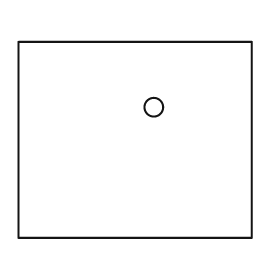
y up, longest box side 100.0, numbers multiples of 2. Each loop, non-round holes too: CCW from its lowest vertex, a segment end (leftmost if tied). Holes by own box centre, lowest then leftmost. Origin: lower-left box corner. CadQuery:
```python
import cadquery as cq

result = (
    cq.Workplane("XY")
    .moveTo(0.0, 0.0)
    .lineTo(100.0, 0.0)
    .lineTo(100.0, 84.0)
    .lineTo(0.0, 84.0)
    .close()
    .moveTo(58.0, 56.0)
    .circle(4.0)
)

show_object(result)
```